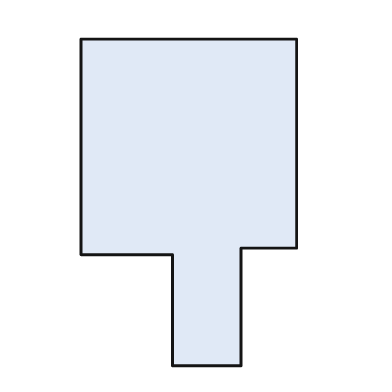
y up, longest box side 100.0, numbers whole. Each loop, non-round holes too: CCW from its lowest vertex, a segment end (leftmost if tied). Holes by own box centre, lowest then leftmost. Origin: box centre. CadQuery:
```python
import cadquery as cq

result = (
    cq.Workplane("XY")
    .moveTo(-5.0, -50.0)
    .lineTo(16.0, -50.0)
    .lineTo(16.0, -14.0)
    .lineTo(33.0, -14.0)
    .lineTo(33.0, 50.0)
    .lineTo(-33.0, 50.0)
    .lineTo(-33.0, -16.0)
    .lineTo(-5.0, -16.0)
    .close()
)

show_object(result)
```